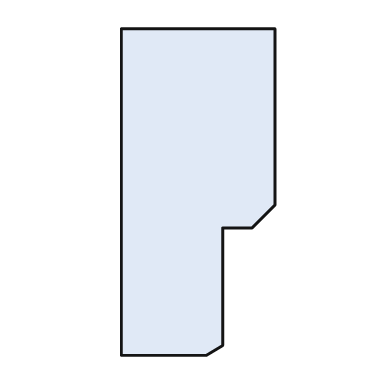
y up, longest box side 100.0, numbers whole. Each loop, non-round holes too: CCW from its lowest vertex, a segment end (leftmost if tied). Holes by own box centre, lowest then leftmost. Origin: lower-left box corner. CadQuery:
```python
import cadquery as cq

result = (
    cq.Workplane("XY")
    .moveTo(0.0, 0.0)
    .lineTo(26.0, 0.0)
    .lineTo(31.0, 3.0)
    .lineTo(31.0, 39.0)
    .lineTo(40.0, 39.0)
    .lineTo(47.0, 46.0)
    .lineTo(47.0, 100.0)
    .lineTo(0.0, 100.0)
    .close()
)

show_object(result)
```